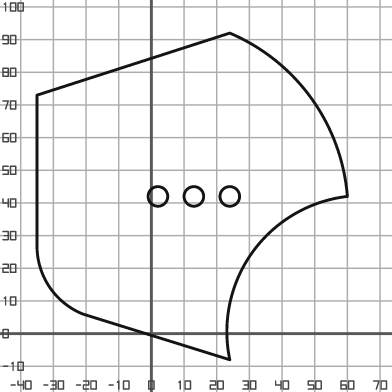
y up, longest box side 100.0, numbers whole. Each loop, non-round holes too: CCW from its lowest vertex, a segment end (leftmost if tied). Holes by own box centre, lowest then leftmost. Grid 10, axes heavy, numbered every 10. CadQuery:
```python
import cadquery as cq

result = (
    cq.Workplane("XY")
    .moveTo(24.0, -8.0)
    .threePointArc((31.0, 25.0), (60.0, 42.0))
    .threePointArc((49.0, 72.0), (24.0, 92.0))
    .lineTo(-35.0, 73.0)
    .lineTo(-35.0, 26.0)
    .threePointArc((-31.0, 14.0), (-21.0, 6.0))
    .close()
    .moveTo(2.0, 42.0)
    .circle(3.0)
    .moveTo(13.0, 42.0)
    .circle(3.0)
    .moveTo(24.0, 42.0)
    .circle(3.0)
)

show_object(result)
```